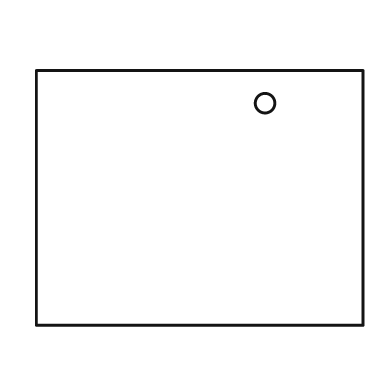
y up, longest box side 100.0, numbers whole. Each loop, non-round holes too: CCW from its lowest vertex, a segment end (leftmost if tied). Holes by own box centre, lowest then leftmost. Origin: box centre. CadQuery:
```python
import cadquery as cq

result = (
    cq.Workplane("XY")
    .moveTo(-50.0, -39.0)
    .lineTo(50.0, -39.0)
    .lineTo(50.0, 39.0)
    .lineTo(-50.0, 39.0)
    .close()
    .moveTo(20.0, 29.0)
    .circle(3.0)
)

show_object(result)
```